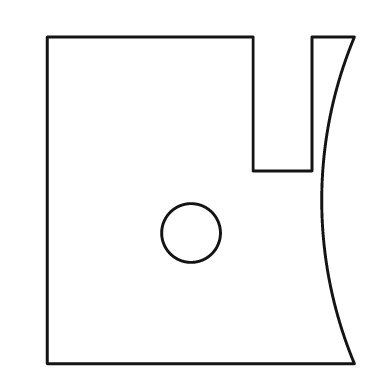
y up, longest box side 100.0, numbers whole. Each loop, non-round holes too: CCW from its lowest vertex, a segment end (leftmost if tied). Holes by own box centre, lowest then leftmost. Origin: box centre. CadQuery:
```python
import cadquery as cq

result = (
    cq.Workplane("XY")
    .moveTo(-47.0, -50.0)
    .lineTo(47.0, -50.0)
    .threePointArc((37.0, 0.0), (47.0, 50.0))
    .lineTo(34.0, 50.0)
    .lineTo(34.0, 9.0)
    .lineTo(16.0, 9.0)
    .lineTo(16.0, 50.0)
    .lineTo(-47.0, 50.0)
    .close()
    .moveTo(-3.0, -10.0)
    .circle(9.0)
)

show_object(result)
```